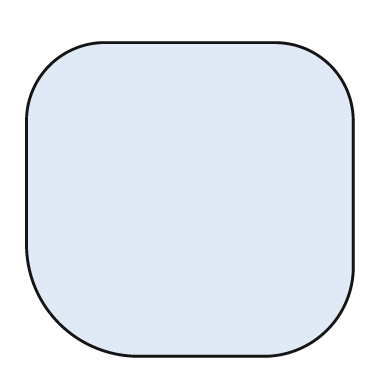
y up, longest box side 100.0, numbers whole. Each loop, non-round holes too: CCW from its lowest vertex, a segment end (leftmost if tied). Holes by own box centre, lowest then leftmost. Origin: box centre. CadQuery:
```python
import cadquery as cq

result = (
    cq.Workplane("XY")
    .moveTo(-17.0, -48.0)
    .lineTo(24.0, -48.0)
    .threePointArc((42.0, -40.0), (50.0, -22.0))
    .lineTo(50.0, 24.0)
    .threePointArc((43.0, 41.0), (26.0, 48.0))
    .lineTo(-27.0, 48.0)
    .threePointArc((-43.0, 41.0), (-50.0, 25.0))
    .lineTo(-50.0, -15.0)
    .threePointArc((-40.0, -38.0), (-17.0, -48.0))
    .close()
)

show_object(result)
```